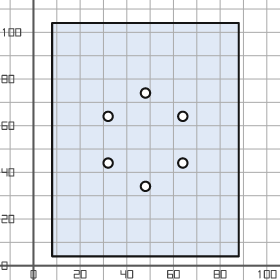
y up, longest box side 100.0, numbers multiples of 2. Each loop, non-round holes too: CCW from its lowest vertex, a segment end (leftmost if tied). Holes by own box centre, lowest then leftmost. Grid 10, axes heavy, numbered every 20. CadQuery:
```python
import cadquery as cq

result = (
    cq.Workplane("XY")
    .moveTo(8.0, 4.0)
    .lineTo(88.0, 4.0)
    .lineTo(88.0, 104.0)
    .lineTo(8.0, 104.0)
    .close()
    .moveTo(48.0, 34.0)
    .circle(2.0)
    .moveTo(32.0, 44.0)
    .circle(2.0)
    .moveTo(64.0, 44.0)
    .circle(2.0)
    .moveTo(32.0, 64.0)
    .circle(2.0)
    .moveTo(64.0, 64.0)
    .circle(2.0)
    .moveTo(48.0, 74.0)
    .circle(2.0)
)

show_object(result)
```